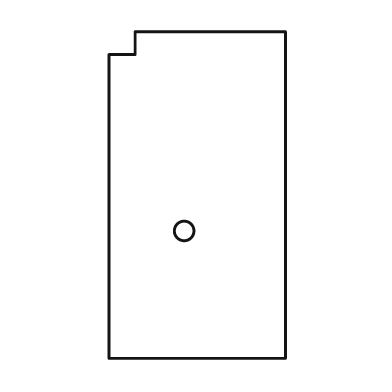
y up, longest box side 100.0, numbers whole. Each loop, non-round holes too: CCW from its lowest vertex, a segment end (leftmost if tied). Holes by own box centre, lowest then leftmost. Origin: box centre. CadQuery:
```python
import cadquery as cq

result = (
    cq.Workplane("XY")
    .moveTo(-27.0, -50.0)
    .lineTo(27.0, -50.0)
    .lineTo(27.0, 50.0)
    .lineTo(-19.0, 50.0)
    .lineTo(-19.0, 43.0)
    .lineTo(-27.0, 43.0)
    .close()
    .moveTo(-4.0, -11.0)
    .circle(3.0)
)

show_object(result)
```